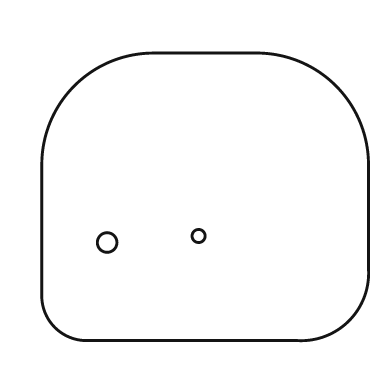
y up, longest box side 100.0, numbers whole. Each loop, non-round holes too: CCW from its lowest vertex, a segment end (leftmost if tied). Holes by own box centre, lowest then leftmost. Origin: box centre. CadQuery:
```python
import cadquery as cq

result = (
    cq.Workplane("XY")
    .moveTo(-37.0, -44.0)
    .lineTo(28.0, -44.0)
    .threePointArc((44.0, -38.0), (50.0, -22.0))
    .lineTo(50.0, 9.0)
    .threePointArc((40.0, 34.0), (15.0, 44.0))
    .lineTo(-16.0, 44.0)
    .threePointArc((-40.0, 34.0), (-50.0, 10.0))
    .lineTo(-50.0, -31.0)
    .threePointArc((-46.0, -40.0), (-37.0, -44.0))
    .close()
    .moveTo(-30.0, -14.0)
    .circle(3.0)
    .moveTo(-2.0, -12.0)
    .circle(2.0)
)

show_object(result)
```